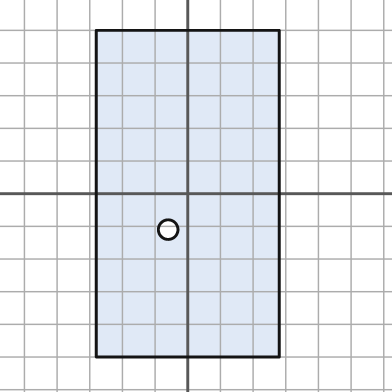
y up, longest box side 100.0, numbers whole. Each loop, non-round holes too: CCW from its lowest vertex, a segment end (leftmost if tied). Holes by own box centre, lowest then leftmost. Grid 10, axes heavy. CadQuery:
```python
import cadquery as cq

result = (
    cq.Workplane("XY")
    .moveTo(-28.0, -50.0)
    .lineTo(28.0, -50.0)
    .lineTo(28.0, 50.0)
    .lineTo(-28.0, 50.0)
    .close()
    .moveTo(-6.0, -11.0)
    .circle(3.0)
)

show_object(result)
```